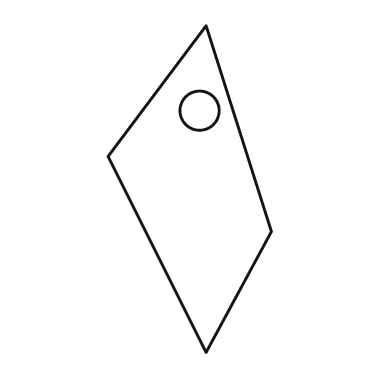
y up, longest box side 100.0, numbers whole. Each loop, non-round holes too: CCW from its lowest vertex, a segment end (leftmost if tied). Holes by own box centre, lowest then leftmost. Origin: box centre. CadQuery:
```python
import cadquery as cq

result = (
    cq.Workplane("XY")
    .moveTo(5.0, -50.0)
    .lineTo(25.0, -13.0)
    .lineTo(5.0, 50.0)
    .lineTo(-25.0, 10.0)
    .close()
    .moveTo(3.0, 24.0)
    .circle(6.0)
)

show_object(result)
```